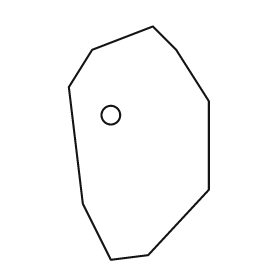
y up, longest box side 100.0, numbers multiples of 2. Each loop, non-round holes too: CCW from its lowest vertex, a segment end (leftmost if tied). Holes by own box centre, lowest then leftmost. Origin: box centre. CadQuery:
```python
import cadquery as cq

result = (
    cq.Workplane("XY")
    .moveTo(-12.0, -50.0)
    .lineTo(4.0, -48.0)
    .lineTo(30.0, -20.0)
    .lineTo(30.0, 18.0)
    .lineTo(16.0, 40.0)
    .lineTo(6.0, 50.0)
    .lineTo(-20.0, 40.0)
    .lineTo(-30.0, 24.0)
    .lineTo(-24.0, -26.0)
    .close()
    .moveTo(-12.0, 12.0)
    .circle(4.0)
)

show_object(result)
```